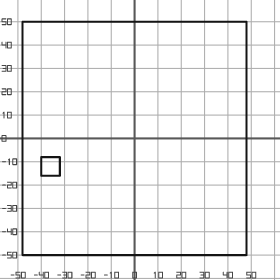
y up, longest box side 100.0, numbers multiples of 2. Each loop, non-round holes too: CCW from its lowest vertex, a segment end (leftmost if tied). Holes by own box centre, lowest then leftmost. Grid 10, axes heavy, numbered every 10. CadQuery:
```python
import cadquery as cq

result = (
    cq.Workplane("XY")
    .moveTo(-48.0, -50.0)
    .lineTo(48.0, -50.0)
    .lineTo(48.0, 50.0)
    .lineTo(-48.0, 50.0)
    .close()
    .moveTo(-40.0, -16.0)
    .lineTo(-32.0, -16.0)
    .lineTo(-32.0, -8.0)
    .lineTo(-40.0, -8.0)
    .close()
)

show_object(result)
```